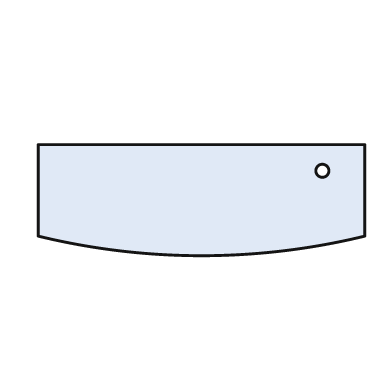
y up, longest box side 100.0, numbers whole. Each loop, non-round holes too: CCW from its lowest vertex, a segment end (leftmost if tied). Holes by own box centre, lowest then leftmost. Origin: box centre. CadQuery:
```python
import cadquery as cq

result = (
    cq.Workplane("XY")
    .moveTo(-50.0, -11.0)
    .threePointArc((0.0, -17.0), (50.0, -11.0))
    .lineTo(50.0, 17.0)
    .lineTo(-50.0, 17.0)
    .close()
    .moveTo(37.0, 9.0)
    .circle(2.0)
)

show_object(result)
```